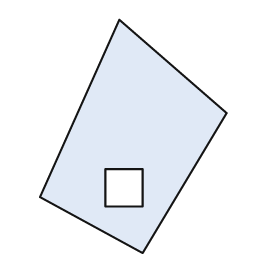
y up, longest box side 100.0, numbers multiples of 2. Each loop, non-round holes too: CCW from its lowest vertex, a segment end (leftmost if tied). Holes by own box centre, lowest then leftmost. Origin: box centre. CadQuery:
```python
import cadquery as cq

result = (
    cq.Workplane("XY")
    .moveTo(4.0, -50.0)
    .lineTo(40.0, 10.0)
    .lineTo(-6.0, 50.0)
    .lineTo(-40.0, -26.0)
    .close()
    .moveTo(-12.0, -30.0)
    .lineTo(4.0, -30.0)
    .lineTo(4.0, -14.0)
    .lineTo(-12.0, -14.0)
    .close()
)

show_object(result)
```